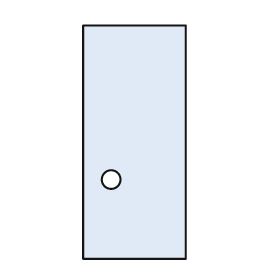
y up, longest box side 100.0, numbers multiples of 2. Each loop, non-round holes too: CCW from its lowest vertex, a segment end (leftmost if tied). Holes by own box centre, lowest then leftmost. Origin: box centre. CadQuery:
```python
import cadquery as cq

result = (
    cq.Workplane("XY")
    .moveTo(-22.0, -50.0)
    .lineTo(22.0, -50.0)
    .lineTo(22.0, 50.0)
    .lineTo(-22.0, 50.0)
    .close()
    .moveTo(-10.0, -16.0)
    .circle(4.0)
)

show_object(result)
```